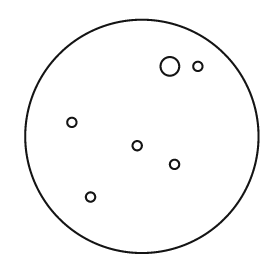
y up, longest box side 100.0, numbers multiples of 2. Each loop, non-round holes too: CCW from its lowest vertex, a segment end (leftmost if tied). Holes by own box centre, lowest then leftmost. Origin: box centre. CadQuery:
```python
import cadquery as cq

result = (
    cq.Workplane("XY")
    .moveTo(0.0, 0.0)
    .circle(50.0)
    .moveTo(-22.0, -26.0)
    .circle(2.0)
    .moveTo(14.0, -12.0)
    .circle(2.0)
    .moveTo(-2.0, -4.0)
    .circle(2.0)
    .moveTo(-30.0, 6.0)
    .circle(2.0)
    .moveTo(12.0, 30.0)
    .circle(4.0)
    .moveTo(24.0, 30.0)
    .circle(2.0)
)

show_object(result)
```